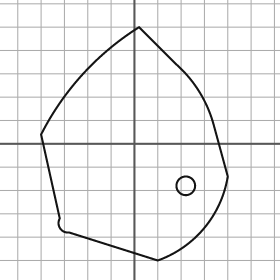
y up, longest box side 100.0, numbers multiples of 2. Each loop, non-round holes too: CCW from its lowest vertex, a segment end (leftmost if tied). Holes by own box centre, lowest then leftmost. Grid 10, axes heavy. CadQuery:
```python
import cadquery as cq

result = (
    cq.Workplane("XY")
    .moveTo(10.0, -50.0)
    .threePointArc((30.0, -36.0), (40.0, -14.0))
    .lineTo(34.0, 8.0)
    .threePointArc((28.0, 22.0), (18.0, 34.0))
    .lineTo(2.0, 50.0)
    .threePointArc((-22.0, 30.0), (-40.0, 4.0))
    .lineTo(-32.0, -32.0)
    .threePointArc((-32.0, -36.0), (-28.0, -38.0))
    .close()
    .moveTo(22.0, -18.0)
    .circle(4.0)
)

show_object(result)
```